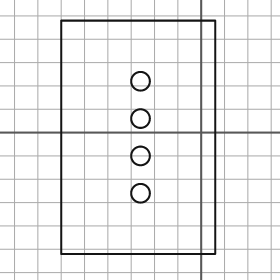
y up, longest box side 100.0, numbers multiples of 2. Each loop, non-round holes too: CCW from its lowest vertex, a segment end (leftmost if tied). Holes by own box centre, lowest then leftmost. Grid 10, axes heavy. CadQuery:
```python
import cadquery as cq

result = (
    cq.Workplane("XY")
    .moveTo(-60.0, -52.0)
    .lineTo(6.0, -52.0)
    .lineTo(6.0, 48.0)
    .lineTo(-60.0, 48.0)
    .close()
    .moveTo(-26.0, -26.0)
    .circle(4.0)
    .moveTo(-26.0, -10.0)
    .circle(4.0)
    .moveTo(-26.0, 6.0)
    .circle(4.0)
    .moveTo(-26.0, 22.0)
    .circle(4.0)
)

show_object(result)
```